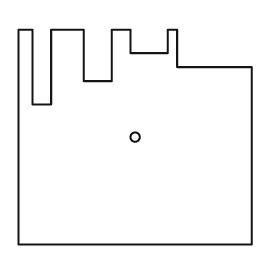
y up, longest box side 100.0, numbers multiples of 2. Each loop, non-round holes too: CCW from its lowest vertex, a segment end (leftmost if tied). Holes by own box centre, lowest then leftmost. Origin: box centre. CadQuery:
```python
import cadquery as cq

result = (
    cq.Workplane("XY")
    .moveTo(-50.0, -46.0)
    .lineTo(50.0, -46.0)
    .lineTo(50.0, 30.0)
    .lineTo(18.0, 30.0)
    .lineTo(18.0, 46.0)
    .lineTo(14.0, 46.0)
    .lineTo(14.0, 36.0)
    .lineTo(-2.0, 36.0)
    .lineTo(-2.0, 46.0)
    .lineTo(-10.0, 46.0)
    .lineTo(-10.0, 24.0)
    .lineTo(-22.0, 24.0)
    .lineTo(-22.0, 46.0)
    .lineTo(-36.0, 46.0)
    .lineTo(-36.0, 14.0)
    .lineTo(-44.0, 14.0)
    .lineTo(-44.0, 46.0)
    .lineTo(-50.0, 46.0)
    .close()
    .moveTo(0.0, 0.0)
    .circle(2.0)
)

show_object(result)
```